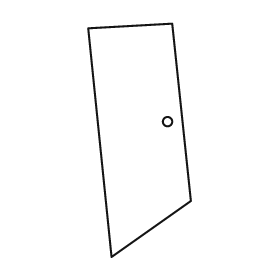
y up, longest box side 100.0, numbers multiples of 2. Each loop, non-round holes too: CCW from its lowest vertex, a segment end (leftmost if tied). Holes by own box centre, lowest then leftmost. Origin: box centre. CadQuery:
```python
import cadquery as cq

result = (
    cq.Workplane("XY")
    .moveTo(-12.0, -50.0)
    .lineTo(22.0, -26.0)
    .lineTo(14.0, 50.0)
    .lineTo(-22.0, 48.0)
    .close()
    .moveTo(12.0, 8.0)
    .circle(2.0)
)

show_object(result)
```